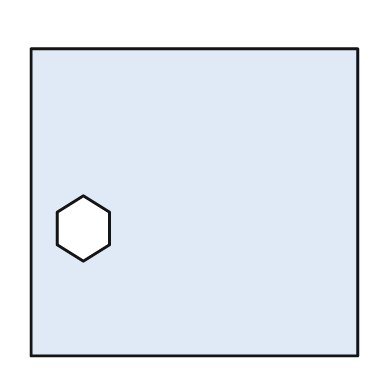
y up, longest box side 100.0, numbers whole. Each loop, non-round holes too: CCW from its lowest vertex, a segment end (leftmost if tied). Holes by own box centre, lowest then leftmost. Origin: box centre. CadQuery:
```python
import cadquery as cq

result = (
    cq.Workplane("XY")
    .moveTo(-50.0, -47.0)
    .lineTo(50.0, -47.0)
    .lineTo(50.0, 47.0)
    .lineTo(-50.0, 47.0)
    .close()
    .moveTo(-34.0, -18.0)
    .lineTo(-26.0, -13.0)
    .lineTo(-26.0, -3.0)
    .lineTo(-34.0, 2.0)
    .lineTo(-42.0, -3.0)
    .lineTo(-42.0, -13.0)
    .close()
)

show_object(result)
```